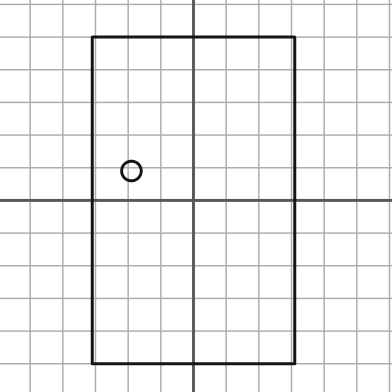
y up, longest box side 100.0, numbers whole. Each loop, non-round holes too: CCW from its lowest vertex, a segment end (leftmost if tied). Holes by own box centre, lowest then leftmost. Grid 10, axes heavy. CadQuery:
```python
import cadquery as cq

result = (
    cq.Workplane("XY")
    .moveTo(-31.0, -50.0)
    .lineTo(31.0, -50.0)
    .lineTo(31.0, 50.0)
    .lineTo(-31.0, 50.0)
    .close()
    .moveTo(-19.0, 9.0)
    .circle(3.0)
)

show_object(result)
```